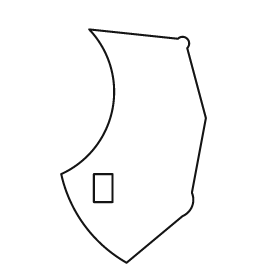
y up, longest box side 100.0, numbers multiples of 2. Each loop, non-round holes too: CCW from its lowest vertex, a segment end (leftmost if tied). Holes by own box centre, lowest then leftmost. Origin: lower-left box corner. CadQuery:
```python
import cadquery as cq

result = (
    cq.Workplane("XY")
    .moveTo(28.0, 0.0)
    .lineTo(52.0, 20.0)
    .threePointArc((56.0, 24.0), (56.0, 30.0))
    .lineTo(62.0, 62.0)
    .lineTo(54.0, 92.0)
    .threePointArc((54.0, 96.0), (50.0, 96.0))
    .lineTo(12.0, 100.0)
    .threePointArc((22.0, 66.0), (0.0, 38.0))
    .threePointArc((10.0, 16.0), (28.0, 0.0))
    .close()
    .moveTo(14.0, 26.0)
    .lineTo(22.0, 26.0)
    .lineTo(22.0, 38.0)
    .lineTo(14.0, 38.0)
    .close()
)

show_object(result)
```